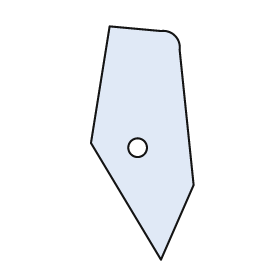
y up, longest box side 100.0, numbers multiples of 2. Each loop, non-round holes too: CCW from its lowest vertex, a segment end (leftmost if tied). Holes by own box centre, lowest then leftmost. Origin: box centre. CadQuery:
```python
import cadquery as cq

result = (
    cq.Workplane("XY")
    .moveTo(8.0, -50.0)
    .lineTo(22.0, -18.0)
    .lineTo(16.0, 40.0)
    .threePointArc((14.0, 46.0), (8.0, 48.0))
    .lineTo(-14.0, 50.0)
    .lineTo(-22.0, 0.0)
    .close()
    .moveTo(-2.0, -2.0)
    .circle(4.0)
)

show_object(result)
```